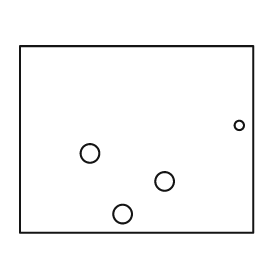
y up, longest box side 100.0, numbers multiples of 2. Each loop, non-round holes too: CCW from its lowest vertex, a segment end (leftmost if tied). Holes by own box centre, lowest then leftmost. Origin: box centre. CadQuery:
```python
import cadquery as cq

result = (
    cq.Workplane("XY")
    .moveTo(-50.0, -40.0)
    .lineTo(50.0, -40.0)
    .lineTo(50.0, 40.0)
    .lineTo(-50.0, 40.0)
    .close()
    .moveTo(-6.0, -32.0)
    .circle(4.0)
    .moveTo(12.0, -18.0)
    .circle(4.0)
    .moveTo(-20.0, -6.0)
    .circle(4.0)
    .moveTo(44.0, 6.0)
    .circle(2.0)
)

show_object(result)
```